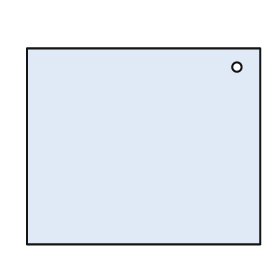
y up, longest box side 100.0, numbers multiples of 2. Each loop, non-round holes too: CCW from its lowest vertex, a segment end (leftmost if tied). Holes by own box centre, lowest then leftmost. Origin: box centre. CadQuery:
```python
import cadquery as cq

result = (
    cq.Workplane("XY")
    .moveTo(-50.0, -42.0)
    .lineTo(50.0, -42.0)
    .lineTo(50.0, 42.0)
    .lineTo(-50.0, 42.0)
    .close()
    .moveTo(40.0, 34.0)
    .circle(2.0)
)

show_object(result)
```